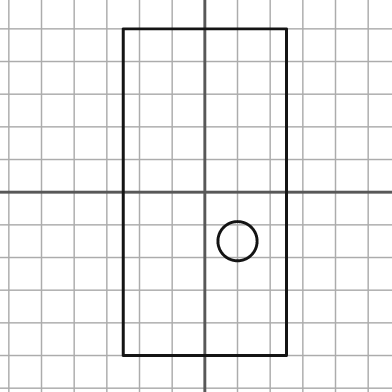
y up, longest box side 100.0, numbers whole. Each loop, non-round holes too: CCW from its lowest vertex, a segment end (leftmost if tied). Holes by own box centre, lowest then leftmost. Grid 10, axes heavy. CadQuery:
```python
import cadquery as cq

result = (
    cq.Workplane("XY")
    .moveTo(-25.0, -50.0)
    .lineTo(25.0, -50.0)
    .lineTo(25.0, 50.0)
    .lineTo(-25.0, 50.0)
    .close()
    .moveTo(10.0, -15.0)
    .circle(6.0)
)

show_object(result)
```